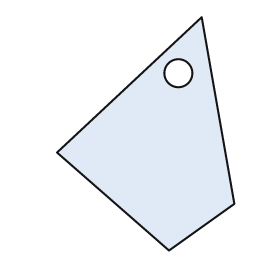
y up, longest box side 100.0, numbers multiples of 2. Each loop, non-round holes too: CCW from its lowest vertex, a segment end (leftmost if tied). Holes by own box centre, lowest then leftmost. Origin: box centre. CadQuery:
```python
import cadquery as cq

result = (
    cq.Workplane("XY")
    .moveTo(10.0, -50.0)
    .lineTo(38.0, -30.0)
    .lineTo(24.0, 50.0)
    .lineTo(-38.0, -8.0)
    .close()
    .moveTo(14.0, 26.0)
    .circle(6.0)
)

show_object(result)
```